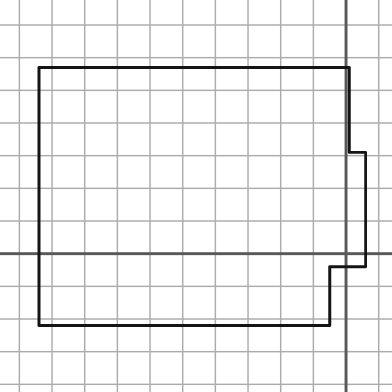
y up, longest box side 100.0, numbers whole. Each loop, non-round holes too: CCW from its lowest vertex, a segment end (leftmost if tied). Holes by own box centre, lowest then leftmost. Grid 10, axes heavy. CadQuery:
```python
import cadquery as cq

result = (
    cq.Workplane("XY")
    .moveTo(-94.0, -22.0)
    .lineTo(-5.0, -22.0)
    .lineTo(-5.0, -4.0)
    .lineTo(6.0, -4.0)
    .lineTo(6.0, 31.0)
    .lineTo(1.0, 31.0)
    .lineTo(1.0, 57.0)
    .lineTo(-94.0, 57.0)
    .close()
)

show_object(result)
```